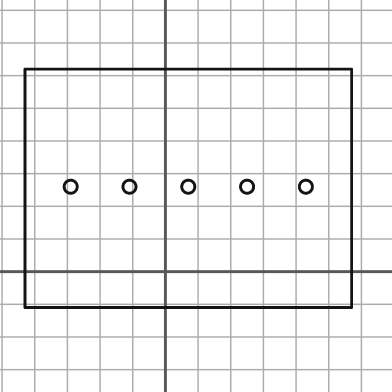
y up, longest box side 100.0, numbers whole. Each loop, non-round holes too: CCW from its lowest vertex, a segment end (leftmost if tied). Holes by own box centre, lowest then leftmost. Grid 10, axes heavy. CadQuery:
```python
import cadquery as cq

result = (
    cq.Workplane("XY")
    .moveTo(-43.0, -11.0)
    .lineTo(57.0, -11.0)
    .lineTo(57.0, 62.0)
    .lineTo(-43.0, 62.0)
    .close()
    .moveTo(-29.0, 26.0)
    .circle(2.0)
    .moveTo(-11.0, 26.0)
    .circle(2.0)
    .moveTo(7.0, 26.0)
    .circle(2.0)
    .moveTo(25.0, 26.0)
    .circle(2.0)
    .moveTo(43.0, 26.0)
    .circle(2.0)
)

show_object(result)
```